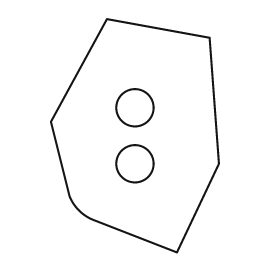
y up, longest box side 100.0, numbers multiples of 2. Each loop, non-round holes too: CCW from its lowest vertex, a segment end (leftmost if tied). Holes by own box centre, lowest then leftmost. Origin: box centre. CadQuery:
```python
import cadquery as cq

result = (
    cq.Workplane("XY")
    .moveTo(18.0, -50.0)
    .lineTo(36.0, -12.0)
    .lineTo(32.0, 42.0)
    .lineTo(-12.0, 50.0)
    .lineTo(-36.0, 6.0)
    .lineTo(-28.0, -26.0)
    .threePointArc((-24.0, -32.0), (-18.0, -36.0))
    .close()
    .moveTo(0.0, -12.0)
    .circle(8.0)
    .moveTo(0.0, 12.0)
    .circle(8.0)
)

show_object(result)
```